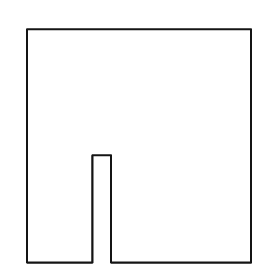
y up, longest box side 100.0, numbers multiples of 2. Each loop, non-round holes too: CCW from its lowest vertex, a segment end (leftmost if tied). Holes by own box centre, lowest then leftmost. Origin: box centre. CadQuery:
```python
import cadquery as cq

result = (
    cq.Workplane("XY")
    .moveTo(-48.0, -50.0)
    .lineTo(-20.0, -50.0)
    .lineTo(-20.0, -4.0)
    .lineTo(-12.0, -4.0)
    .lineTo(-12.0, -50.0)
    .lineTo(48.0, -50.0)
    .lineTo(48.0, 50.0)
    .lineTo(-48.0, 50.0)
    .close()
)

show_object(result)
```